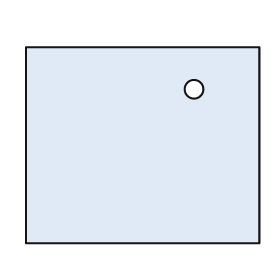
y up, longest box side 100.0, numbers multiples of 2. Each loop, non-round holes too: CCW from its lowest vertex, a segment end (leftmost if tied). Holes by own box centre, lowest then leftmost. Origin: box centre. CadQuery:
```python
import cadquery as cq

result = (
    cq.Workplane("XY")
    .moveTo(-50.0, -42.0)
    .lineTo(50.0, -42.0)
    .lineTo(50.0, 42.0)
    .lineTo(-50.0, 42.0)
    .close()
    .moveTo(22.0, 24.0)
    .circle(4.0)
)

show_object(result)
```